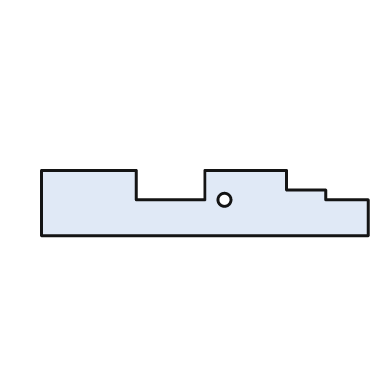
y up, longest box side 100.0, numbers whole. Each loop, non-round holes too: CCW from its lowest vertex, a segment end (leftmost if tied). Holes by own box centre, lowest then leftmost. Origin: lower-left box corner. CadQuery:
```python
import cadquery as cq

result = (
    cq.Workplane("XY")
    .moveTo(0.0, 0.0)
    .lineTo(100.0, 0.0)
    .lineTo(100.0, 11.0)
    .lineTo(87.0, 11.0)
    .lineTo(87.0, 14.0)
    .lineTo(75.0, 14.0)
    .lineTo(75.0, 20.0)
    .lineTo(50.0, 20.0)
    .lineTo(50.0, 11.0)
    .lineTo(29.0, 11.0)
    .lineTo(29.0, 20.0)
    .lineTo(0.0, 20.0)
    .close()
    .moveTo(56.0, 11.0)
    .circle(2.0)
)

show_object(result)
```